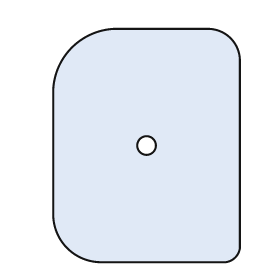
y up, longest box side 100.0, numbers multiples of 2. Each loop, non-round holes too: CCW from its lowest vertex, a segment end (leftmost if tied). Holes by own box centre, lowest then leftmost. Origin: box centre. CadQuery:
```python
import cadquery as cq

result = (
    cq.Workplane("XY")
    .moveTo(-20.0, -50.0)
    .lineTo(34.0, -50.0)
    .threePointArc((38.0, -48.0), (40.0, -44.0))
    .lineTo(40.0, 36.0)
    .threePointArc((36.0, 46.0), (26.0, 50.0))
    .lineTo(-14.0, 50.0)
    .threePointArc((-32.0, 42.0), (-40.0, 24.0))
    .lineTo(-40.0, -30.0)
    .threePointArc((-34.0, -44.0), (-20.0, -50.0))
    .close()
    .moveTo(0.0, 0.0)
    .circle(4.0)
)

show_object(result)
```